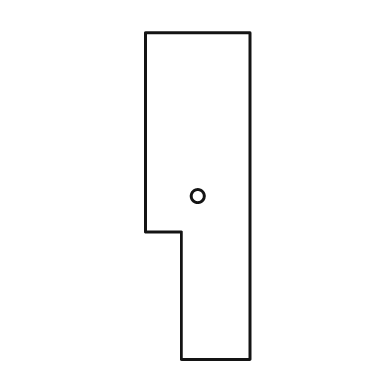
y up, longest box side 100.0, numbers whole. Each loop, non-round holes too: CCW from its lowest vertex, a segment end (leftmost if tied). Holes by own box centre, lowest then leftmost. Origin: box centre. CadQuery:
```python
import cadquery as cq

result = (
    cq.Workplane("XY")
    .moveTo(-5.0, -50.0)
    .lineTo(16.0, -50.0)
    .lineTo(16.0, 50.0)
    .lineTo(-16.0, 50.0)
    .lineTo(-16.0, -11.0)
    .lineTo(-5.0, -11.0)
    .close()
    .moveTo(0.0, 0.0)
    .circle(2.0)
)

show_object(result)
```